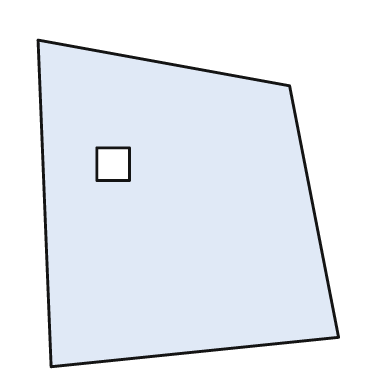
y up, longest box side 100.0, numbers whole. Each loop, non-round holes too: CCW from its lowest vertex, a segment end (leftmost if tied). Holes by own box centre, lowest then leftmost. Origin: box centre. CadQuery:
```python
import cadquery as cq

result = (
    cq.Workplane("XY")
    .moveTo(-42.0, -50.0)
    .lineTo(46.0, -41.0)
    .lineTo(31.0, 36.0)
    .lineTo(-46.0, 50.0)
    .close()
    .moveTo(-28.0, 7.0)
    .lineTo(-18.0, 7.0)
    .lineTo(-18.0, 17.0)
    .lineTo(-28.0, 17.0)
    .close()
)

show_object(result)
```